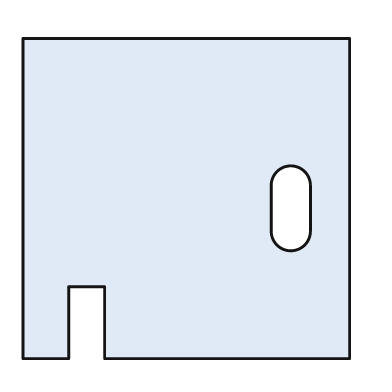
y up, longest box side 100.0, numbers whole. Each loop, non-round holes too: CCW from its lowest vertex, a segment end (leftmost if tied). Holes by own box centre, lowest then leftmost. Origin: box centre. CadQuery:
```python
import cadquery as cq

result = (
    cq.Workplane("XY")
    .moveTo(-50.0, -49.0)
    .lineTo(-36.0, -49.0)
    .lineTo(-36.0, -27.0)
    .lineTo(-25.0, -27.0)
    .lineTo(-25.0, -49.0)
    .lineTo(50.0, -49.0)
    .lineTo(50.0, 49.0)
    .lineTo(-50.0, 49.0)
    .close()
    .moveTo(26.0, -10.0)
    .threePointArc((32.0, -16.0), (38.0, -10.0))
    .lineTo(38.0, 4.0)
    .threePointArc((32.0, 10.0), (26.0, 4.0))
    .close()
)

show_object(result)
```